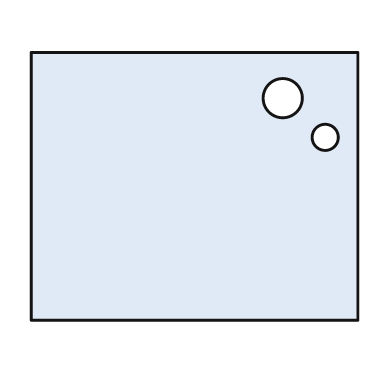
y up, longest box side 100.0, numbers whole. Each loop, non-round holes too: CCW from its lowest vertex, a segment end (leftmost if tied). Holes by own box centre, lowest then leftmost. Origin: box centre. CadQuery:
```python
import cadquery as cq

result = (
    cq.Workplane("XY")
    .moveTo(-50.0, -41.0)
    .lineTo(50.0, -41.0)
    .lineTo(50.0, 41.0)
    .lineTo(-50.0, 41.0)
    .close()
    .moveTo(40.0, 15.0)
    .circle(4.0)
    .moveTo(27.0, 27.0)
    .circle(6.0)
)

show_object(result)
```